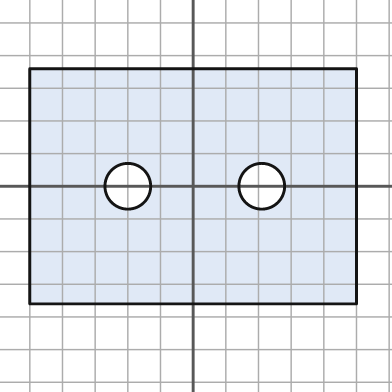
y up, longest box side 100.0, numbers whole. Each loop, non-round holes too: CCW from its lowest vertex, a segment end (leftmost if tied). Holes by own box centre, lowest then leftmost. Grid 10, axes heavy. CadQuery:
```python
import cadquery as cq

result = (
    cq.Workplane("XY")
    .moveTo(-50.0, -36.0)
    .lineTo(50.0, -36.0)
    .lineTo(50.0, 36.0)
    .lineTo(-50.0, 36.0)
    .close()
    .moveTo(-20.0, 0.0)
    .circle(7.0)
    .moveTo(21.0, 0.0)
    .circle(7.0)
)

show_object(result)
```